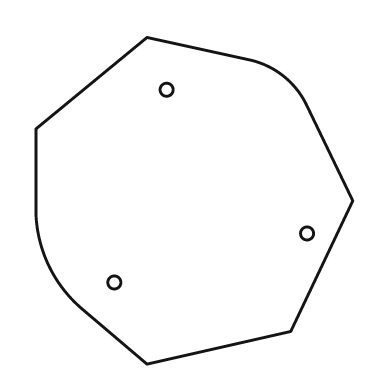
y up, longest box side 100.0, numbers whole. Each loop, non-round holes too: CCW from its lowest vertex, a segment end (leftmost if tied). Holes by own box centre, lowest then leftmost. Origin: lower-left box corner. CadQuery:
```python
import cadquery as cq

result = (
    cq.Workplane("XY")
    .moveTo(34.0, 0.0)
    .lineTo(78.0, 10.0)
    .lineTo(97.0, 50.0)
    .lineTo(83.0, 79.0)
    .threePointArc((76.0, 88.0), (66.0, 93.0))
    .lineTo(34.0, 100.0)
    .lineTo(0.0, 72.0)
    .lineTo(0.0, 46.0)
    .threePointArc((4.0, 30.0), (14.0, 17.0))
    .close()
    .moveTo(24.0, 25.0)
    .circle(2.0)
    .moveTo(83.0, 40.0)
    .circle(2.0)
    .moveTo(40.0, 84.0)
    .circle(2.0)
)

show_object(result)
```